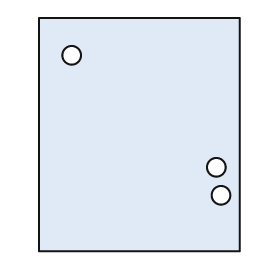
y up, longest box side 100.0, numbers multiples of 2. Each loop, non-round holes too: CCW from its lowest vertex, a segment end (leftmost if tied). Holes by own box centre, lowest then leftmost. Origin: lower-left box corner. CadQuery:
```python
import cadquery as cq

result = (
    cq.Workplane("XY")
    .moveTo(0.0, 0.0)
    .lineTo(86.0, 0.0)
    .lineTo(86.0, 100.0)
    .lineTo(0.0, 100.0)
    .close()
    .moveTo(78.0, 24.0)
    .circle(4.0)
    .moveTo(76.0, 36.0)
    .circle(4.0)
    .moveTo(14.0, 84.0)
    .circle(4.0)
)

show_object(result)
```